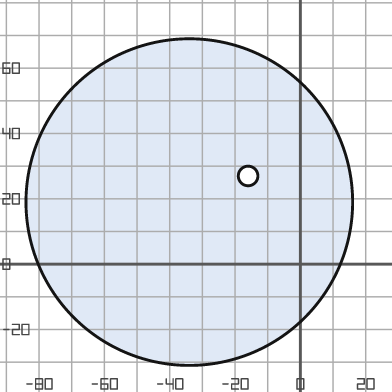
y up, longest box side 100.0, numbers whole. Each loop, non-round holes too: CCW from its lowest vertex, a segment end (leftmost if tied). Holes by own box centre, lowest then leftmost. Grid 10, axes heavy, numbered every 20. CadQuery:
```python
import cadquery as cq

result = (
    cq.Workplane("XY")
    .moveTo(-34.0, 19.0)
    .circle(50.0)
    .moveTo(-16.0, 27.0)
    .circle(3.0)
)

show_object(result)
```